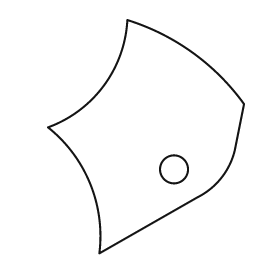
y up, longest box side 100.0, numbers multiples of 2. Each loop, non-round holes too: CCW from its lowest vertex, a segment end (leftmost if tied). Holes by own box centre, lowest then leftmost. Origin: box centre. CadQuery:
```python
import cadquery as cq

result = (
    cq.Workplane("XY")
    .moveTo(-20.0, -50.0)
    .lineTo(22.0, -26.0)
    .threePointArc((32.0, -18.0), (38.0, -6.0))
    .lineTo(42.0, 14.0)
    .threePointArc((20.0, 36.0), (-8.0, 50.0))
    .threePointArc((-18.0, 22.0), (-42.0, 4.0))
    .threePointArc((-24.0, -20.0), (-20.0, -50.0))
    .close()
    .moveTo(12.0, -14.0)
    .circle(6.0)
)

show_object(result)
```